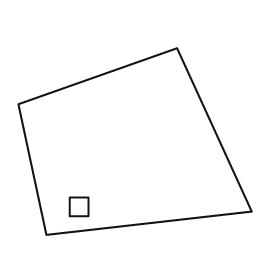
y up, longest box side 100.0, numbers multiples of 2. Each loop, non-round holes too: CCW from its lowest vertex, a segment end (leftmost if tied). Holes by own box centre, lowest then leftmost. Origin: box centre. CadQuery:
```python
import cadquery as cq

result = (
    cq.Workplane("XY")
    .moveTo(-38.0, -40.0)
    .lineTo(50.0, -30.0)
    .lineTo(18.0, 40.0)
    .lineTo(-50.0, 16.0)
    .close()
    .moveTo(-28.0, -32.0)
    .lineTo(-20.0, -32.0)
    .lineTo(-20.0, -24.0)
    .lineTo(-28.0, -24.0)
    .close()
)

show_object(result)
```